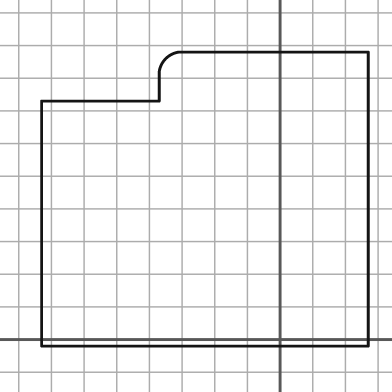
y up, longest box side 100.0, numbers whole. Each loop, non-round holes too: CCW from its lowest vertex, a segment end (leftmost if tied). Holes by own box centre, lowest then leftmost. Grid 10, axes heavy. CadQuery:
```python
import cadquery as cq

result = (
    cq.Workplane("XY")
    .moveTo(-73.0, -2.0)
    .lineTo(27.0, -2.0)
    .lineTo(27.0, 88.0)
    .lineTo(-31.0, 88.0)
    .threePointArc((-35.0, 86.0), (-37.0, 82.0))
    .lineTo(-37.0, 73.0)
    .lineTo(-73.0, 73.0)
    .close()
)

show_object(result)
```